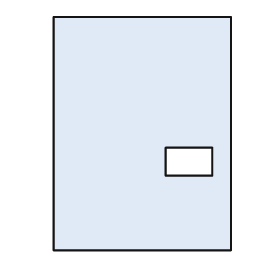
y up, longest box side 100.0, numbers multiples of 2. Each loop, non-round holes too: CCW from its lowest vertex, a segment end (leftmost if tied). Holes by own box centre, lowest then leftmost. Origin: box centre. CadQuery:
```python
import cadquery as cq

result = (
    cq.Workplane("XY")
    .moveTo(-38.0, -50.0)
    .lineTo(38.0, -50.0)
    .lineTo(38.0, 50.0)
    .lineTo(-38.0, 50.0)
    .close()
    .moveTo(10.0, -18.0)
    .lineTo(30.0, -18.0)
    .lineTo(30.0, -6.0)
    .lineTo(10.0, -6.0)
    .close()
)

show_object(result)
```